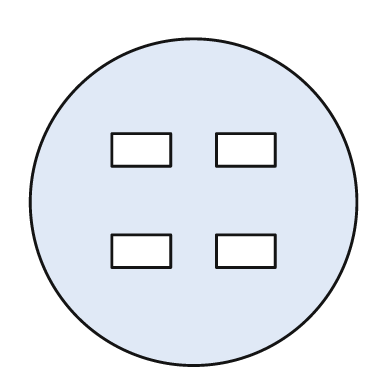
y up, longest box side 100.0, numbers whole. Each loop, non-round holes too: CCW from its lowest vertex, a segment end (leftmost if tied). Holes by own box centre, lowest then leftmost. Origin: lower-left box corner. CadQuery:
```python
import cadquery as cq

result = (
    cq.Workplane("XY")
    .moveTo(50.0, 50.0)
    .circle(50.0)
    .moveTo(25.0, 30.0)
    .lineTo(43.0, 30.0)
    .lineTo(43.0, 40.0)
    .lineTo(25.0, 40.0)
    .close()
    .moveTo(57.0, 30.0)
    .lineTo(75.0, 30.0)
    .lineTo(75.0, 40.0)
    .lineTo(57.0, 40.0)
    .close()
    .moveTo(25.0, 61.0)
    .lineTo(43.0, 61.0)
    .lineTo(43.0, 71.0)
    .lineTo(25.0, 71.0)
    .close()
    .moveTo(57.0, 61.0)
    .lineTo(75.0, 61.0)
    .lineTo(75.0, 71.0)
    .lineTo(57.0, 71.0)
    .close()
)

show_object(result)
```